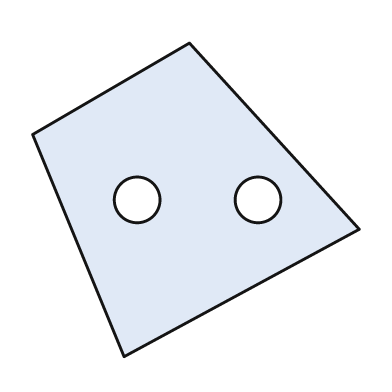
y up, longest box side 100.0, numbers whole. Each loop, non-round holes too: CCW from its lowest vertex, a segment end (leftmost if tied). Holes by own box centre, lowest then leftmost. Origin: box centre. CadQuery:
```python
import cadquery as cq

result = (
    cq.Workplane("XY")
    .moveTo(-22.0, -48.0)
    .lineTo(50.0, -9.0)
    .lineTo(-2.0, 48.0)
    .lineTo(-50.0, 20.0)
    .close()
    .moveTo(-18.0, 0.0)
    .circle(7.0)
    .moveTo(19.0, 0.0)
    .circle(7.0)
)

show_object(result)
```